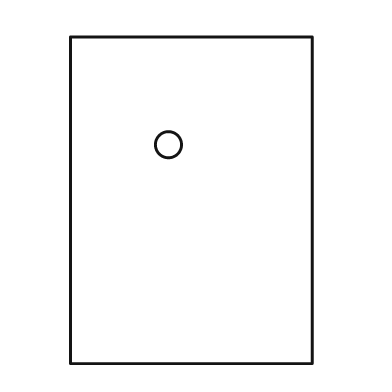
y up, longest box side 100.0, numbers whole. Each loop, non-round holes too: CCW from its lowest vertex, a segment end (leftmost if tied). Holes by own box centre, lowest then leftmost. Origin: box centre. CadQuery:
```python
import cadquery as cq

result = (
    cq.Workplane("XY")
    .moveTo(-37.0, -50.0)
    .lineTo(37.0, -50.0)
    .lineTo(37.0, 50.0)
    .lineTo(-37.0, 50.0)
    .close()
    .moveTo(-7.0, 17.0)
    .circle(4.0)
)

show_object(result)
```